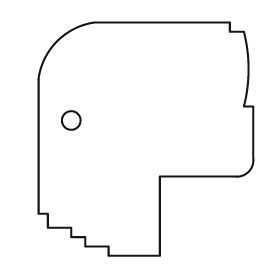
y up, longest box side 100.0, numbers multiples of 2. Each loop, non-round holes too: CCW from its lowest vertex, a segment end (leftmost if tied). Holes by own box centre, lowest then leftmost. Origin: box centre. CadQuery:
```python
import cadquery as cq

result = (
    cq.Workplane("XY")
    .moveTo(-16.0, -50.0)
    .lineTo(6.0, -50.0)
    .lineTo(6.0, -16.0)
    .lineTo(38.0, -16.0)
    .threePointArc((44.0, -14.0), (46.0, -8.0))
    .lineTo(46.0, 14.0)
    .lineTo(42.0, 14.0)
    .threePointArc((44.0, 30.0), (42.0, 46.0))
    .lineTo(36.0, 46.0)
    .lineTo(36.0, 50.0)
    .lineTo(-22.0, 50.0)
    .threePointArc((-38.0, 42.0), (-46.0, 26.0))
    .lineTo(-46.0, -32.0)
    .lineTo(-42.0, -32.0)
    .lineTo(-42.0, -38.0)
    .lineTo(-32.0, -38.0)
    .lineTo(-32.0, -42.0)
    .lineTo(-26.0, -42.0)
    .lineTo(-26.0, -46.0)
    .lineTo(-16.0, -46.0)
    .close()
    .moveTo(-32.0, 8.0)
    .circle(4.0)
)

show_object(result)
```